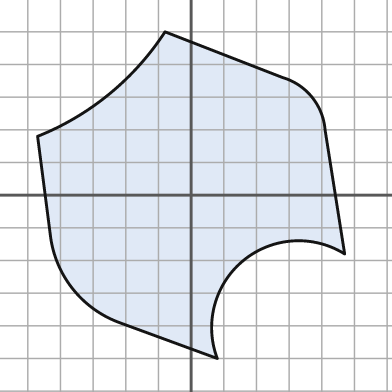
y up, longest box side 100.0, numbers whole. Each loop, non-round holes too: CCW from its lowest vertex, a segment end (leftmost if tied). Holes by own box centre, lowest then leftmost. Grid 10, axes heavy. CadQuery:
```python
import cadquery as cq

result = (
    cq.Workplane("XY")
    .moveTo(8.0, -50.0)
    .threePointArc((16.0, -20.0), (47.0, -18.0))
    .lineTo(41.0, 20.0)
    .threePointArc((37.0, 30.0), (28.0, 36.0))
    .lineTo(-8.0, 50.0)
    .threePointArc((-25.0, 31.0), (-47.0, 18.0))
    .lineTo(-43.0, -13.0)
    .threePointArc((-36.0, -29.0), (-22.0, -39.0))
    .close()
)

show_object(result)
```